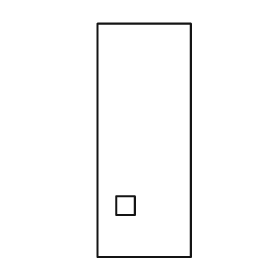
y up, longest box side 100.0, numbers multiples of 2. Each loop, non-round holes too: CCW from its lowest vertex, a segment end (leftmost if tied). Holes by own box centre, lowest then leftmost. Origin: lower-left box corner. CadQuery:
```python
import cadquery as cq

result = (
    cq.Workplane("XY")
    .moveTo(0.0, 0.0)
    .lineTo(40.0, 0.0)
    .lineTo(40.0, 100.0)
    .lineTo(0.0, 100.0)
    .close()
    .moveTo(8.0, 18.0)
    .lineTo(16.0, 18.0)
    .lineTo(16.0, 26.0)
    .lineTo(8.0, 26.0)
    .close()
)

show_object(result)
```